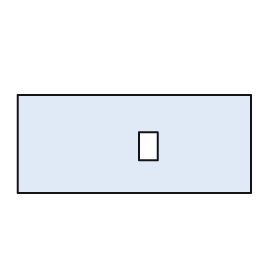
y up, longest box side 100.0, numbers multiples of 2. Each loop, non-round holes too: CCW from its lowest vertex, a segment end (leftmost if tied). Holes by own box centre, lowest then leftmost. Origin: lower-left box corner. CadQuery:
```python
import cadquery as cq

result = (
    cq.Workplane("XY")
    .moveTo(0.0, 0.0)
    .lineTo(100.0, 0.0)
    .lineTo(100.0, 42.0)
    .lineTo(0.0, 42.0)
    .close()
    .moveTo(52.0, 14.0)
    .lineTo(60.0, 14.0)
    .lineTo(60.0, 26.0)
    .lineTo(52.0, 26.0)
    .close()
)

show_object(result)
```